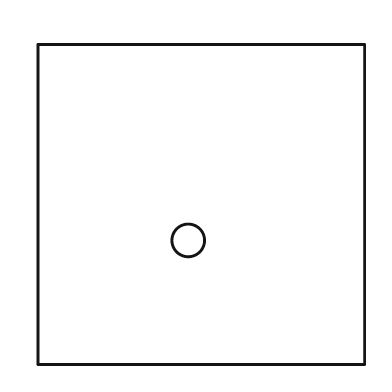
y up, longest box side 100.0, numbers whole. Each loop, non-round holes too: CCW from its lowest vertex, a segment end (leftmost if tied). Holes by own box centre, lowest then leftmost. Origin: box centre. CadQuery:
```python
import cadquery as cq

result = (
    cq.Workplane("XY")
    .moveTo(-50.0, -49.0)
    .lineTo(50.0, -49.0)
    .lineTo(50.0, 49.0)
    .lineTo(-50.0, 49.0)
    .close()
    .moveTo(-4.0, -11.0)
    .circle(5.0)
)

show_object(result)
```